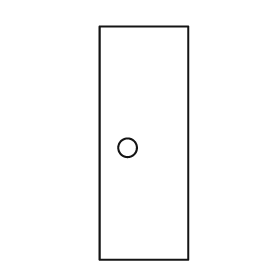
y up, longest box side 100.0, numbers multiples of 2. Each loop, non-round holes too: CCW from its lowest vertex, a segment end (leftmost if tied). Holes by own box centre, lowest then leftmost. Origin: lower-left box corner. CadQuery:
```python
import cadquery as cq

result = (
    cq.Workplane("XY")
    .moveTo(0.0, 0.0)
    .lineTo(38.0, 0.0)
    .lineTo(38.0, 100.0)
    .lineTo(0.0, 100.0)
    .close()
    .moveTo(12.0, 48.0)
    .circle(4.0)
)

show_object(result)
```